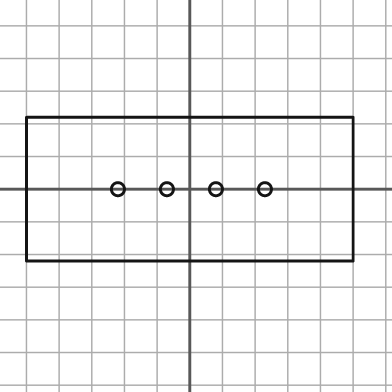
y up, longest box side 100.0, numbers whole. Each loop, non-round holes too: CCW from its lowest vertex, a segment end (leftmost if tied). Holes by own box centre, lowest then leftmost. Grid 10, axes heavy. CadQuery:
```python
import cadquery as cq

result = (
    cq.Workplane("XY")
    .moveTo(-50.0, -22.0)
    .lineTo(50.0, -22.0)
    .lineTo(50.0, 22.0)
    .lineTo(-50.0, 22.0)
    .close()
    .moveTo(-22.0, 0.0)
    .circle(2.0)
    .moveTo(-7.0, 0.0)
    .circle(2.0)
    .moveTo(8.0, 0.0)
    .circle(2.0)
    .moveTo(23.0, 0.0)
    .circle(2.0)
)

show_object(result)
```